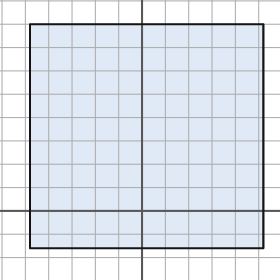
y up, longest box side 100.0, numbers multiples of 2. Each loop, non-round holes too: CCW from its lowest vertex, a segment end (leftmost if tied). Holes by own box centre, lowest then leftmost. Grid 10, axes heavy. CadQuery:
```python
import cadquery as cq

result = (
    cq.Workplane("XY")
    .moveTo(-48.0, -16.0)
    .lineTo(52.0, -16.0)
    .lineTo(52.0, 80.0)
    .lineTo(-48.0, 80.0)
    .close()
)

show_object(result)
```